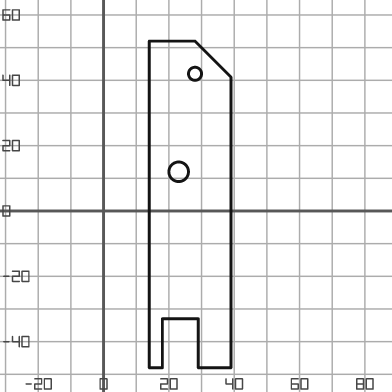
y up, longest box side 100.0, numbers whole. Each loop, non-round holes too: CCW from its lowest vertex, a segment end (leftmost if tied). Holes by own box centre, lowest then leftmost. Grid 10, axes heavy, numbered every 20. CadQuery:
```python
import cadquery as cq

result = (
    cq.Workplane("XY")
    .moveTo(14.0, -48.0)
    .lineTo(18.0, -48.0)
    .lineTo(18.0, -33.0)
    .lineTo(29.0, -33.0)
    .lineTo(29.0, -48.0)
    .lineTo(39.0, -48.0)
    .lineTo(39.0, 41.0)
    .lineTo(28.0, 52.0)
    .lineTo(14.0, 52.0)
    .close()
    .moveTo(23.0, 12.0)
    .circle(3.0)
    .moveTo(28.0, 42.0)
    .circle(2.0)
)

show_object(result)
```